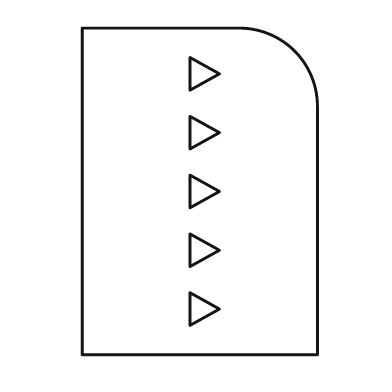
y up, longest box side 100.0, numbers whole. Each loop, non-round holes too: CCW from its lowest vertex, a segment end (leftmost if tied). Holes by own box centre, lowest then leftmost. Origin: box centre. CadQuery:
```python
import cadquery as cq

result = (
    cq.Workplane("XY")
    .moveTo(-36.0, -50.0)
    .lineTo(36.0, -50.0)
    .lineTo(36.0, 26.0)
    .threePointArc((29.0, 43.0), (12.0, 50.0))
    .lineTo(-36.0, 50.0)
    .close()
    .moveTo(-3.0, -41.0)
    .lineTo(6.0, -36.0)
    .lineTo(-3.0, -31.0)
    .close()
    .moveTo(-3.0, -23.0)
    .lineTo(6.0, -18.0)
    .lineTo(-3.0, -13.0)
    .close()
    .moveTo(-3.0, -5.0)
    .lineTo(6.0, 0.0)
    .lineTo(-3.0, 5.0)
    .close()
    .moveTo(-3.0, 13.0)
    .lineTo(6.0, 18.0)
    .lineTo(-3.0, 23.0)
    .close()
    .moveTo(-3.0, 31.0)
    .lineTo(6.0, 36.0)
    .lineTo(-3.0, 41.0)
    .close()
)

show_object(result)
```